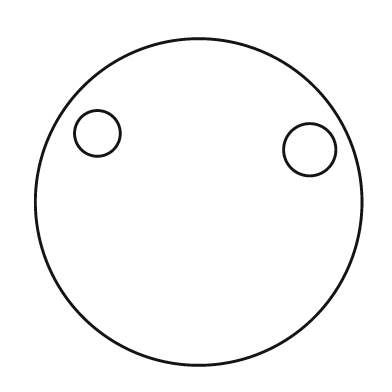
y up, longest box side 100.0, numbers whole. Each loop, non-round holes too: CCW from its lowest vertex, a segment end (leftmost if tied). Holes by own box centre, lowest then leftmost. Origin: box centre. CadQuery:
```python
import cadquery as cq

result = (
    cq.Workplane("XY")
    .moveTo(0.0, 0.0)
    .circle(50.0)
    .moveTo(34.0, 16.0)
    .circle(8.0)
    .moveTo(-31.0, 21.0)
    .circle(7.0)
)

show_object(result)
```